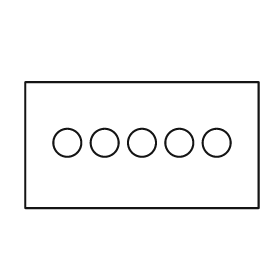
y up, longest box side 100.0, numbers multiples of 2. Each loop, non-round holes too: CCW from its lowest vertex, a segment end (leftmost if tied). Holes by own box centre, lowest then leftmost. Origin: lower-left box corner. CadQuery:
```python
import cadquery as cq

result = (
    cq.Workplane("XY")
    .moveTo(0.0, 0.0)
    .lineTo(100.0, 0.0)
    .lineTo(100.0, 54.0)
    .lineTo(0.0, 54.0)
    .close()
    .moveTo(18.0, 28.0)
    .circle(6.0)
    .moveTo(34.0, 28.0)
    .circle(6.0)
    .moveTo(50.0, 28.0)
    .circle(6.0)
    .moveTo(66.0, 28.0)
    .circle(6.0)
    .moveTo(82.0, 28.0)
    .circle(6.0)
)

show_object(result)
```